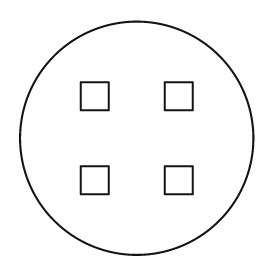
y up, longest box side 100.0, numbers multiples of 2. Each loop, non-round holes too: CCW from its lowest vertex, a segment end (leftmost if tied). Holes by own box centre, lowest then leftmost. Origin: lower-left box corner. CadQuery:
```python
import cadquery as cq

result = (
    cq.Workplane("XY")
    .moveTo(50.0, 50.0)
    .circle(50.0)
    .moveTo(26.0, 26.0)
    .lineTo(38.0, 26.0)
    .lineTo(38.0, 38.0)
    .lineTo(26.0, 38.0)
    .close()
    .moveTo(62.0, 26.0)
    .lineTo(74.0, 26.0)
    .lineTo(74.0, 38.0)
    .lineTo(62.0, 38.0)
    .close()
    .moveTo(26.0, 62.0)
    .lineTo(38.0, 62.0)
    .lineTo(38.0, 74.0)
    .lineTo(26.0, 74.0)
    .close()
    .moveTo(62.0, 62.0)
    .lineTo(74.0, 62.0)
    .lineTo(74.0, 74.0)
    .lineTo(62.0, 74.0)
    .close()
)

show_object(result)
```